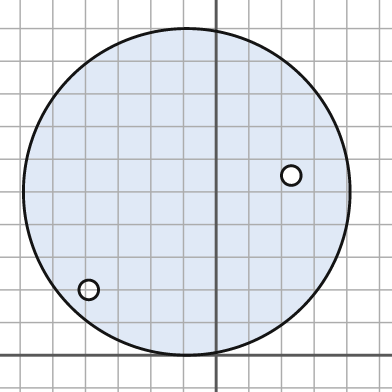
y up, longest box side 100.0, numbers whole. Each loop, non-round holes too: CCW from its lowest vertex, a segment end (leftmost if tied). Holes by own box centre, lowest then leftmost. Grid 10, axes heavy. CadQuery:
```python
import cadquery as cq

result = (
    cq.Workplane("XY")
    .moveTo(-9.0, 50.0)
    .circle(50.0)
    .moveTo(-39.0, 20.0)
    .circle(3.0)
    .moveTo(23.0, 55.0)
    .circle(3.0)
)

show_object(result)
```